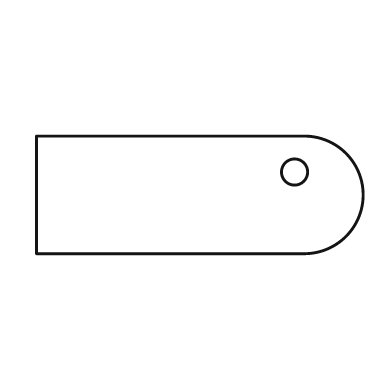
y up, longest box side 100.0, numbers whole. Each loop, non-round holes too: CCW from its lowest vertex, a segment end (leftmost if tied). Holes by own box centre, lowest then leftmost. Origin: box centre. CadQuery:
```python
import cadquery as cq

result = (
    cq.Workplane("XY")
    .moveTo(-50.0, -18.0)
    .lineTo(32.0, -18.0)
    .threePointArc((50.0, 0.0), (32.0, 18.0))
    .lineTo(-50.0, 18.0)
    .close()
    .moveTo(29.0, 7.0)
    .circle(4.0)
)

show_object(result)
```